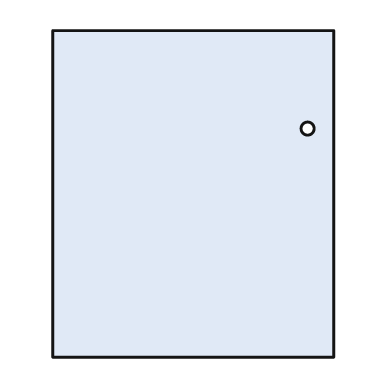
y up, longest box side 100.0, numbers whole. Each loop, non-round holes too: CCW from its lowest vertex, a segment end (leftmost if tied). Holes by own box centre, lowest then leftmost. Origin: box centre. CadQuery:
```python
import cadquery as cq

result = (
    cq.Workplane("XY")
    .moveTo(-43.0, -50.0)
    .lineTo(43.0, -50.0)
    .lineTo(43.0, 50.0)
    .lineTo(-43.0, 50.0)
    .close()
    .moveTo(35.0, 20.0)
    .circle(2.0)
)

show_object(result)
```